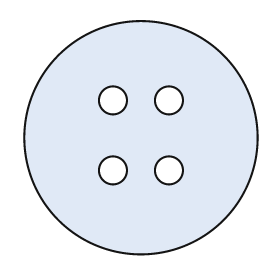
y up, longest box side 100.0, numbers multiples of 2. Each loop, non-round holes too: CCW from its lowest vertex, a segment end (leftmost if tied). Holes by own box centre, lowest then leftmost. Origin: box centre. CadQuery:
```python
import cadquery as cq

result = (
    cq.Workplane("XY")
    .moveTo(0.0, 0.0)
    .circle(50.0)
    .moveTo(-12.0, -14.0)
    .circle(6.0)
    .moveTo(12.0, -14.0)
    .circle(6.0)
    .moveTo(-12.0, 16.0)
    .circle(6.0)
    .moveTo(12.0, 16.0)
    .circle(6.0)
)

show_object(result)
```